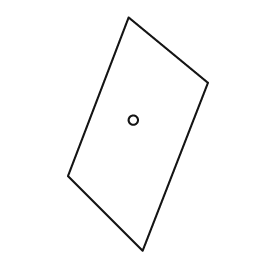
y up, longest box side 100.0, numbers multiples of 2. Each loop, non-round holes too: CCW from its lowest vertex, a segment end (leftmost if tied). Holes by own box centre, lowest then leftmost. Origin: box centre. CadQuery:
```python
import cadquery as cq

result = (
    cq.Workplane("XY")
    .moveTo(2.0, -50.0)
    .lineTo(30.0, 22.0)
    .lineTo(-4.0, 50.0)
    .lineTo(-30.0, -18.0)
    .close()
    .moveTo(-2.0, 6.0)
    .circle(2.0)
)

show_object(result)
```